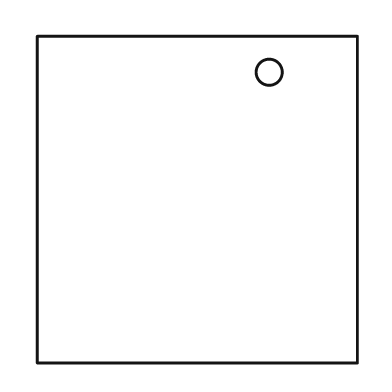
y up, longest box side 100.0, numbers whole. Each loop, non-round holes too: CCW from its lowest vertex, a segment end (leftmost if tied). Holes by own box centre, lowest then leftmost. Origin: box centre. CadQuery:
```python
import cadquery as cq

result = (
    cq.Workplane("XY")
    .moveTo(-49.0, -50.0)
    .lineTo(49.0, -50.0)
    .lineTo(49.0, 50.0)
    .lineTo(-49.0, 50.0)
    .close()
    .moveTo(22.0, 39.0)
    .circle(4.0)
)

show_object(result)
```